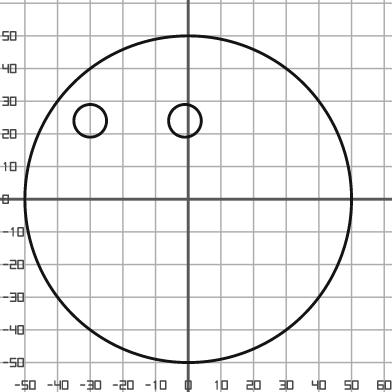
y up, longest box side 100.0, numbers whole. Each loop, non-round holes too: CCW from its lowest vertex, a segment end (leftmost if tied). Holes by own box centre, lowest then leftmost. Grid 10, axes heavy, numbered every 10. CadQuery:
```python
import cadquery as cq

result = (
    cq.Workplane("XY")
    .moveTo(0.0, 0.0)
    .circle(50.0)
    .moveTo(-30.0, 24.0)
    .circle(5.0)
    .moveTo(-1.0, 24.0)
    .circle(5.0)
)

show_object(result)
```